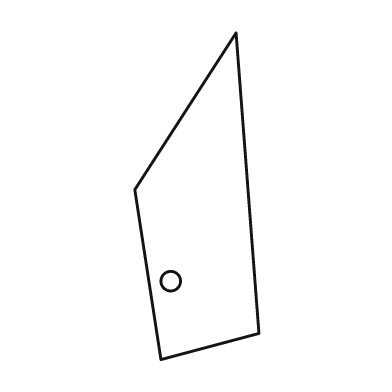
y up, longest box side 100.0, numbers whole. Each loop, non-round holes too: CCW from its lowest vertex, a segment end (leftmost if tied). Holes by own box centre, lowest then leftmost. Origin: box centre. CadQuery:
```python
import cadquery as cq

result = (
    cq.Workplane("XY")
    .moveTo(-11.0, -50.0)
    .lineTo(19.0, -42.0)
    .lineTo(12.0, 50.0)
    .lineTo(-19.0, 2.0)
    .close()
    .moveTo(-8.0, -26.0)
    .circle(3.0)
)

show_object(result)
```